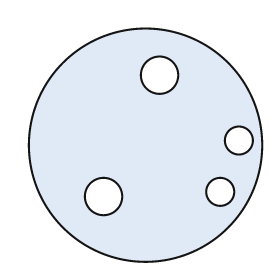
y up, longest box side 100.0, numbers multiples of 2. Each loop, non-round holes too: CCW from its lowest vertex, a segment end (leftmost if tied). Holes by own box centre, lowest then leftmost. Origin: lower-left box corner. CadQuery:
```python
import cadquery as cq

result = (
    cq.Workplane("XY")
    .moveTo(50.0, 50.0)
    .circle(50.0)
    .moveTo(32.0, 28.0)
    .circle(8.0)
    .moveTo(82.0, 30.0)
    .circle(6.0)
    .moveTo(90.0, 52.0)
    .circle(6.0)
    .moveTo(56.0, 80.0)
    .circle(8.0)
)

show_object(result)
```